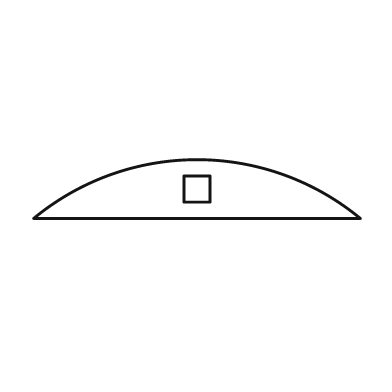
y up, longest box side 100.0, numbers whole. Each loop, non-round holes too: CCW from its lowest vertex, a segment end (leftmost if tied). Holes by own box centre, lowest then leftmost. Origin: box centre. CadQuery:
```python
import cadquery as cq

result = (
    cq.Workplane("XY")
    .moveTo(-50.0, -9.0)
    .lineTo(50.0, -9.0)
    .threePointArc((0.0, 9.0), (-50.0, -9.0))
    .close()
    .moveTo(-4.0, -4.0)
    .lineTo(4.0, -4.0)
    .lineTo(4.0, 4.0)
    .lineTo(-4.0, 4.0)
    .close()
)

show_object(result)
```